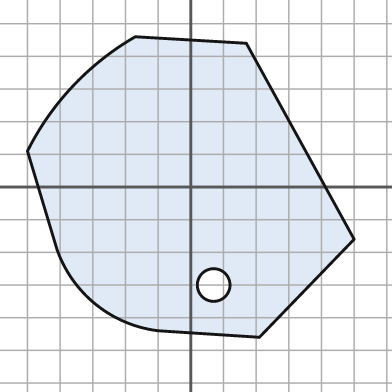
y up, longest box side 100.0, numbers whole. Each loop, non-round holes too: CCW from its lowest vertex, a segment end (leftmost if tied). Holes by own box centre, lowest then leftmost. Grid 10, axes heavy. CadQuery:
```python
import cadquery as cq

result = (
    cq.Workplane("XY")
    .moveTo(21.0, -46.0)
    .lineTo(50.0, -16.0)
    .lineTo(17.0, 44.0)
    .lineTo(-17.0, 46.0)
    .threePointArc((-36.0, 31.0), (-50.0, 11.0))
    .lineTo(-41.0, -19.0)
    .threePointArc((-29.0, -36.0), (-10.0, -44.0))
    .close()
    .moveTo(7.0, -30.0)
    .circle(5.0)
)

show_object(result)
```